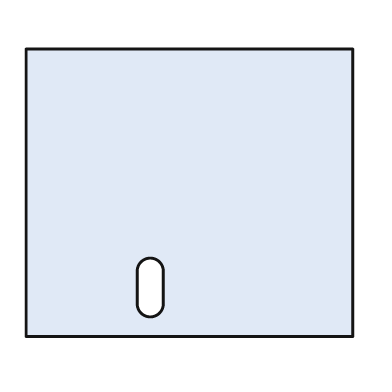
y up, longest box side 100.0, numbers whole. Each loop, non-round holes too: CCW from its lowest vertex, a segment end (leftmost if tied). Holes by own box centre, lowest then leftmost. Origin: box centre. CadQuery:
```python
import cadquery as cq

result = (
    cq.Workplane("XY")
    .moveTo(-50.0, -44.0)
    .lineTo(50.0, -44.0)
    .lineTo(50.0, 44.0)
    .lineTo(-50.0, 44.0)
    .close()
    .moveTo(-16.0, -34.0)
    .threePointArc((-12.0, -38.0), (-8.0, -34.0))
    .lineTo(-8.0, -24.0)
    .threePointArc((-12.0, -20.0), (-16.0, -24.0))
    .close()
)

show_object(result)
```